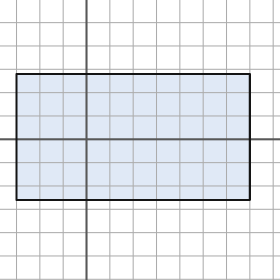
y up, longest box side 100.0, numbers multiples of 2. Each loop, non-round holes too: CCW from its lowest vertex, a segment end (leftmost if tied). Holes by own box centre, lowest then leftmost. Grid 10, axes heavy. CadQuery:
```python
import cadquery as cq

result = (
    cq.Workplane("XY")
    .moveTo(-30.0, -26.0)
    .lineTo(70.0, -26.0)
    .lineTo(70.0, 28.0)
    .lineTo(-30.0, 28.0)
    .close()
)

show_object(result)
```